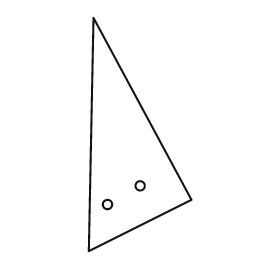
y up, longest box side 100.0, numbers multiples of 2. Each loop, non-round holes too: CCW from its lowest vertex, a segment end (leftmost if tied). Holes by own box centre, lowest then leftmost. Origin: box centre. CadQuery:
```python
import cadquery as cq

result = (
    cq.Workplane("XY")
    .moveTo(-22.0, -50.0)
    .lineTo(22.0, -28.0)
    .lineTo(-20.0, 50.0)
    .close()
    .moveTo(-14.0, -30.0)
    .circle(2.0)
    .moveTo(0.0, -22.0)
    .circle(2.0)
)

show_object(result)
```